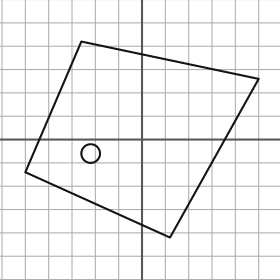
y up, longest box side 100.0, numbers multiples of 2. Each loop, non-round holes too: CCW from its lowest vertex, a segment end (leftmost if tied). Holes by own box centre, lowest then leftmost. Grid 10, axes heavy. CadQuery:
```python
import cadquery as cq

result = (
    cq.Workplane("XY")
    .moveTo(12.0, -42.0)
    .lineTo(50.0, 26.0)
    .lineTo(-26.0, 42.0)
    .lineTo(-50.0, -14.0)
    .close()
    .moveTo(-22.0, -6.0)
    .circle(4.0)
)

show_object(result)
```